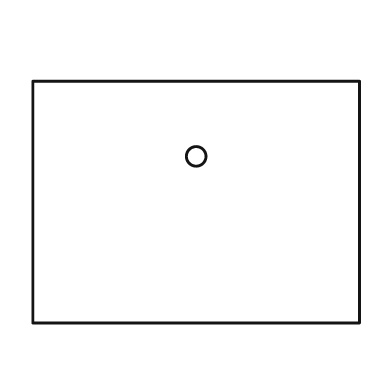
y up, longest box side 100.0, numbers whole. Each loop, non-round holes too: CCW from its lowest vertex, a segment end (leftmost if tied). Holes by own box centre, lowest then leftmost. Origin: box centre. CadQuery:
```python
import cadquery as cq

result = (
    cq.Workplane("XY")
    .moveTo(-50.0, -37.0)
    .lineTo(50.0, -37.0)
    .lineTo(50.0, 37.0)
    .lineTo(-50.0, 37.0)
    .close()
    .moveTo(0.0, 14.0)
    .circle(3.0)
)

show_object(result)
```